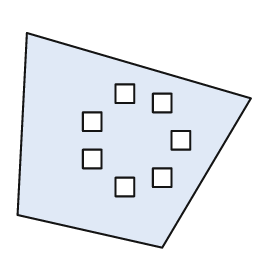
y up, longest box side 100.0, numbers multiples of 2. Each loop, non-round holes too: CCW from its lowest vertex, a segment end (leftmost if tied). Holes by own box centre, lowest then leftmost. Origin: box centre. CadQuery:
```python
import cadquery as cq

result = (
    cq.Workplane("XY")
    .moveTo(12.0, -46.0)
    .lineTo(50.0, 18.0)
    .lineTo(-46.0, 46.0)
    .lineTo(-50.0, -32.0)
    .close()
    .moveTo(-8.0, -24.0)
    .lineTo(0.0, -24.0)
    .lineTo(0.0, -16.0)
    .lineTo(-8.0, -16.0)
    .close()
    .moveTo(8.0, -20.0)
    .lineTo(16.0, -20.0)
    .lineTo(16.0, -12.0)
    .lineTo(8.0, -12.0)
    .close()
    .moveTo(-22.0, -12.0)
    .lineTo(-14.0, -12.0)
    .lineTo(-14.0, -4.0)
    .lineTo(-22.0, -4.0)
    .close()
    .moveTo(16.0, -4.0)
    .lineTo(24.0, -4.0)
    .lineTo(24.0, 4.0)
    .lineTo(16.0, 4.0)
    .close()
    .moveTo(-22.0, 4.0)
    .lineTo(-14.0, 4.0)
    .lineTo(-14.0, 12.0)
    .lineTo(-22.0, 12.0)
    .close()
    .moveTo(8.0, 12.0)
    .lineTo(16.0, 12.0)
    .lineTo(16.0, 20.0)
    .lineTo(8.0, 20.0)
    .close()
    .moveTo(-8.0, 16.0)
    .lineTo(0.0, 16.0)
    .lineTo(0.0, 24.0)
    .lineTo(-8.0, 24.0)
    .close()
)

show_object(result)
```